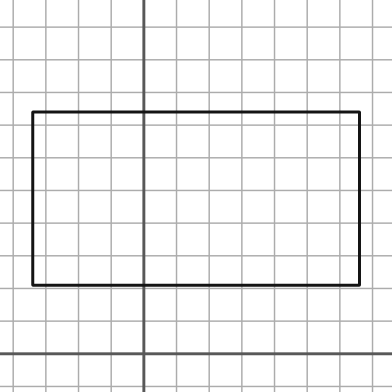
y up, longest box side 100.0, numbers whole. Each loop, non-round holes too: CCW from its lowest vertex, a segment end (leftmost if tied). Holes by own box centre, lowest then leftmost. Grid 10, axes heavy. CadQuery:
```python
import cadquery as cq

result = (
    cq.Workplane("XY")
    .moveTo(-34.0, 21.0)
    .lineTo(66.0, 21.0)
    .lineTo(66.0, 74.0)
    .lineTo(-34.0, 74.0)
    .close()
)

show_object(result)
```